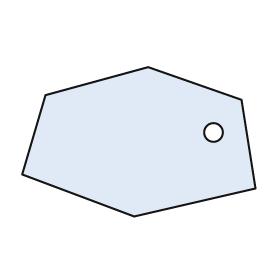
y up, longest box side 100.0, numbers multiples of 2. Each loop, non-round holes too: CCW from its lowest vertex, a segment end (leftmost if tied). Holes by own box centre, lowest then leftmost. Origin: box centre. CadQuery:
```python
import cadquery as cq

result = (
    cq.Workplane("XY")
    .moveTo(-2.0, -32.0)
    .lineTo(50.0, -20.0)
    .lineTo(44.0, 18.0)
    .lineTo(4.0, 32.0)
    .lineTo(-40.0, 20.0)
    .lineTo(-50.0, -14.0)
    .close()
    .moveTo(32.0, 4.0)
    .circle(4.0)
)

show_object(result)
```